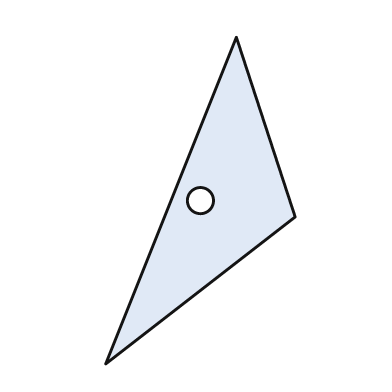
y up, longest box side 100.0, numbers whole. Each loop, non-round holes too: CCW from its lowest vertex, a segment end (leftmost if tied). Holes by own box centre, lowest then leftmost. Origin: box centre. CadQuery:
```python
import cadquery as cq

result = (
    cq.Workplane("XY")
    .moveTo(-29.0, -50.0)
    .lineTo(29.0, -5.0)
    .lineTo(11.0, 50.0)
    .close()
    .moveTo(0.0, 0.0)
    .circle(4.0)
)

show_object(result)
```